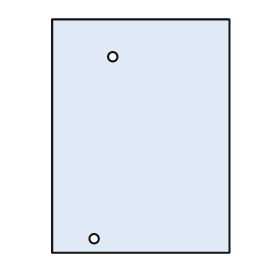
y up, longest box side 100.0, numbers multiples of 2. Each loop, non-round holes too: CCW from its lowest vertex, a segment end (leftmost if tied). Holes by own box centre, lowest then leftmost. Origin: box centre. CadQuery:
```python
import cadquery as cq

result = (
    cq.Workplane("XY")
    .moveTo(-38.0, -50.0)
    .lineTo(38.0, -50.0)
    .lineTo(38.0, 50.0)
    .lineTo(-38.0, 50.0)
    .close()
    .moveTo(-20.0, -44.0)
    .circle(2.0)
    .moveTo(-12.0, 34.0)
    .circle(2.0)
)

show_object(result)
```